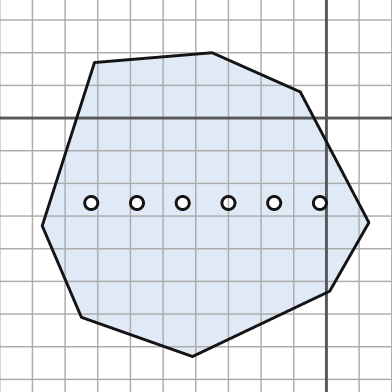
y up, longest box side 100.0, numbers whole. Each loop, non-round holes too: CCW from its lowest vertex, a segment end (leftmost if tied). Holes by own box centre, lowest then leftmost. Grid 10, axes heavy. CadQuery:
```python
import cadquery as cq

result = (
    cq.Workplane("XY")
    .moveTo(-41.0, -73.0)
    .lineTo(1.0, -53.0)
    .lineTo(13.0, -32.0)
    .lineTo(-8.0, 8.0)
    .lineTo(-35.0, 20.0)
    .lineTo(-71.0, 17.0)
    .lineTo(-87.0, -33.0)
    .lineTo(-75.0, -61.0)
    .close()
    .moveTo(-72.0, -26.0)
    .circle(2.0)
    .moveTo(-58.0, -26.0)
    .circle(2.0)
    .moveTo(-44.0, -26.0)
    .circle(2.0)
    .moveTo(-30.0, -26.0)
    .circle(2.0)
    .moveTo(-16.0, -26.0)
    .circle(2.0)
    .moveTo(-2.0, -26.0)
    .circle(2.0)
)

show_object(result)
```